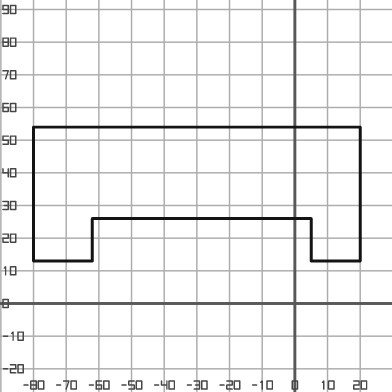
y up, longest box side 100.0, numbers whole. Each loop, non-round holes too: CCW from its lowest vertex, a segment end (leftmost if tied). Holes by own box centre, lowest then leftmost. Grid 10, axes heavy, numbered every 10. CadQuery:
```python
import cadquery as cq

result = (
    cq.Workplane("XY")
    .moveTo(-80.0, 13.0)
    .lineTo(-62.0, 13.0)
    .lineTo(-62.0, 26.0)
    .lineTo(5.0, 26.0)
    .lineTo(5.0, 13.0)
    .lineTo(20.0, 13.0)
    .lineTo(20.0, 54.0)
    .lineTo(-80.0, 54.0)
    .close()
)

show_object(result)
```